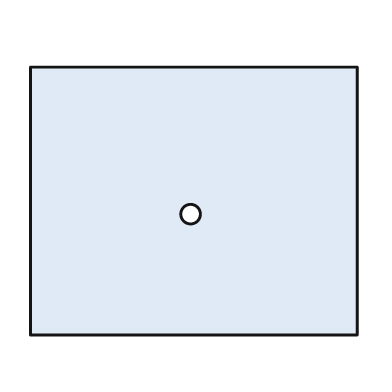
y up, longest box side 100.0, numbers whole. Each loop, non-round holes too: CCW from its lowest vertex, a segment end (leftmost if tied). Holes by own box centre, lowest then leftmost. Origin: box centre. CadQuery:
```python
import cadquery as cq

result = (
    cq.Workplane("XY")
    .moveTo(-50.0, -41.0)
    .lineTo(50.0, -41.0)
    .lineTo(50.0, 41.0)
    .lineTo(-50.0, 41.0)
    .close()
    .moveTo(-1.0, -4.0)
    .circle(3.0)
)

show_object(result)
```